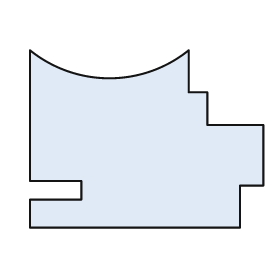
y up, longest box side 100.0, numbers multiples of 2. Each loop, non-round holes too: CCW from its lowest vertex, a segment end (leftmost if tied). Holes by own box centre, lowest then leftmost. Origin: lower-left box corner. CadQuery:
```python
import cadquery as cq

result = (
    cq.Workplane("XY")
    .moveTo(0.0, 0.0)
    .lineTo(90.0, 0.0)
    .lineTo(90.0, 18.0)
    .lineTo(100.0, 18.0)
    .lineTo(100.0, 44.0)
    .lineTo(76.0, 44.0)
    .lineTo(76.0, 58.0)
    .lineTo(68.0, 58.0)
    .lineTo(68.0, 76.0)
    .threePointArc((34.0, 64.0), (0.0, 76.0))
    .lineTo(0.0, 20.0)
    .lineTo(22.0, 20.0)
    .lineTo(22.0, 12.0)
    .lineTo(0.0, 12.0)
    .close()
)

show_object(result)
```